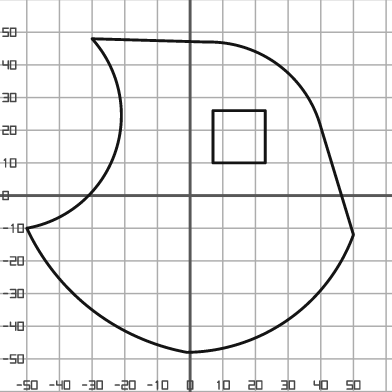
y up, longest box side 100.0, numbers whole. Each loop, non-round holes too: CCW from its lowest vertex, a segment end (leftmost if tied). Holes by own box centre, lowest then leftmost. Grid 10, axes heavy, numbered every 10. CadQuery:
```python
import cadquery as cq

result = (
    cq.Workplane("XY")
    .moveTo(-1.0, -48.0)
    .threePointArc((30.0, -38.0), (50.0, -12.0))
    .lineTo(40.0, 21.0)
    .threePointArc((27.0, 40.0), (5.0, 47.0))
    .lineTo(-30.0, 48.0)
    .threePointArc((-23.0, 13.0), (-50.0, -10.0))
    .threePointArc((-30.0, -35.0), (-1.0, -48.0))
    .close()
    .moveTo(7.0, 10.0)
    .lineTo(23.0, 10.0)
    .lineTo(23.0, 26.0)
    .lineTo(7.0, 26.0)
    .close()
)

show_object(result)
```